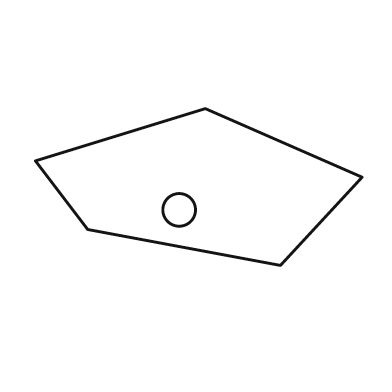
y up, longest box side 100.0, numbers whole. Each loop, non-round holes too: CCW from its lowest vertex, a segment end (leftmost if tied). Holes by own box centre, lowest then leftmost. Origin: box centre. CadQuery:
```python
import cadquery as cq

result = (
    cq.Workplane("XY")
    .moveTo(25.0, -24.0)
    .lineTo(50.0, 3.0)
    .lineTo(2.0, 24.0)
    .lineTo(-50.0, 8.0)
    .lineTo(-34.0, -13.0)
    .close()
    .moveTo(-6.0, -7.0)
    .circle(5.0)
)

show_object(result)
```